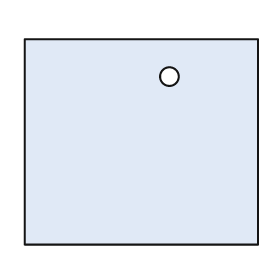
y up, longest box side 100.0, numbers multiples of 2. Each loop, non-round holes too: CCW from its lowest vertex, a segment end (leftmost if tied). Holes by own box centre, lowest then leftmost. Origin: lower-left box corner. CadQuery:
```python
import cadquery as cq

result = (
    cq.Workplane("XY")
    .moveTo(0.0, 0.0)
    .lineTo(100.0, 0.0)
    .lineTo(100.0, 88.0)
    .lineTo(0.0, 88.0)
    .close()
    .moveTo(62.0, 72.0)
    .circle(4.0)
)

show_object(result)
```